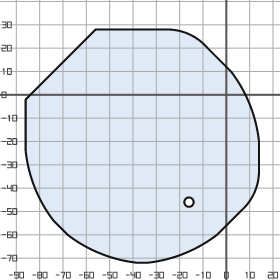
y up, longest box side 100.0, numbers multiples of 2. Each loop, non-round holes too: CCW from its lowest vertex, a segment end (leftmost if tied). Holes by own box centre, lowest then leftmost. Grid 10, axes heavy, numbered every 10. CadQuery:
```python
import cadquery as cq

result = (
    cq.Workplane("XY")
    .moveTo(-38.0, -72.0)
    .lineTo(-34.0, -72.0)
    .threePointArc((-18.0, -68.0), (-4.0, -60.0))
    .lineTo(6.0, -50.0)
    .threePointArc((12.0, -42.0), (14.0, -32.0))
    .lineTo(14.0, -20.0)
    .threePointArc((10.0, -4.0), (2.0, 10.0))
    .lineTo(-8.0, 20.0)
    .threePointArc((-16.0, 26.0), (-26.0, 28.0))
    .lineTo(-56.0, 28.0)
    .lineTo(-86.0, -2.0)
    .lineTo(-86.0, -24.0)
    .threePointArc((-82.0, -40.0), (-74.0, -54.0))
    .lineTo(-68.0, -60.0)
    .threePointArc((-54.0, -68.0), (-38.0, -72.0))
    .close()
    .moveTo(-16.0, -46.0)
    .circle(2.0)
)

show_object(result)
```